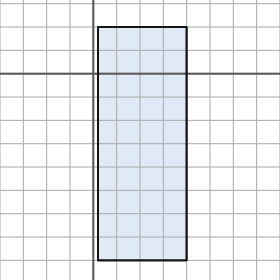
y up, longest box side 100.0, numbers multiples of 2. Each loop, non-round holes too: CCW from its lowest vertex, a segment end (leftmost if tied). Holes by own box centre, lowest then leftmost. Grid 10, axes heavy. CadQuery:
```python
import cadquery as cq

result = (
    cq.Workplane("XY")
    .moveTo(2.0, -80.0)
    .lineTo(40.0, -80.0)
    .lineTo(40.0, 20.0)
    .lineTo(2.0, 20.0)
    .close()
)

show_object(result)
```